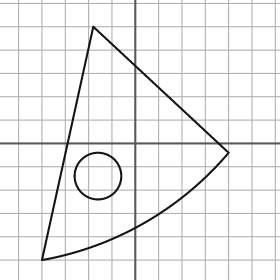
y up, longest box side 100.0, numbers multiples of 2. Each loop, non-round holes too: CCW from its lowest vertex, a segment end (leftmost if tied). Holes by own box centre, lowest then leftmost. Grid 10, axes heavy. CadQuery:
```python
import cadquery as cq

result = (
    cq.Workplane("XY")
    .moveTo(-40.0, -50.0)
    .threePointArc((4.0, -34.0), (40.0, -4.0))
    .lineTo(-18.0, 50.0)
    .close()
    .moveTo(-16.0, -14.0)
    .circle(10.0)
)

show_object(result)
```